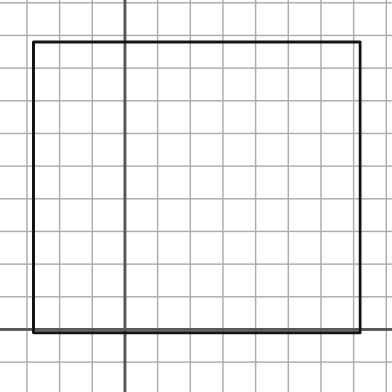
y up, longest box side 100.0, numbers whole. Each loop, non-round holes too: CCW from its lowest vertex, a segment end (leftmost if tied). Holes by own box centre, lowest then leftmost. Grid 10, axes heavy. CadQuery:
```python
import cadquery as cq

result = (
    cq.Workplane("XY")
    .moveTo(-28.0, -1.0)
    .lineTo(72.0, -1.0)
    .lineTo(72.0, 88.0)
    .lineTo(-28.0, 88.0)
    .close()
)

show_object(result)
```